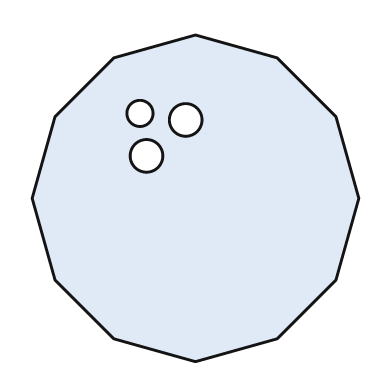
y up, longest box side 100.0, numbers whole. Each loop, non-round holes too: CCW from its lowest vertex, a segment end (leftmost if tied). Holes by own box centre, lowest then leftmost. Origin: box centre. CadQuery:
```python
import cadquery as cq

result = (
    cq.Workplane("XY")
    .moveTo(0.0, -50.0)
    .lineTo(25.0, -43.0)
    .lineTo(43.0, -25.0)
    .lineTo(50.0, 0.0)
    .lineTo(43.0, 25.0)
    .lineTo(25.0, 43.0)
    .lineTo(0.0, 50.0)
    .lineTo(-25.0, 43.0)
    .lineTo(-43.0, 25.0)
    .lineTo(-50.0, 0.0)
    .lineTo(-43.0, -25.0)
    .lineTo(-25.0, -43.0)
    .close()
    .moveTo(-15.0, 13.0)
    .circle(5.0)
    .moveTo(-3.0, 24.0)
    .circle(5.0)
    .moveTo(-17.0, 26.0)
    .circle(4.0)
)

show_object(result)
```